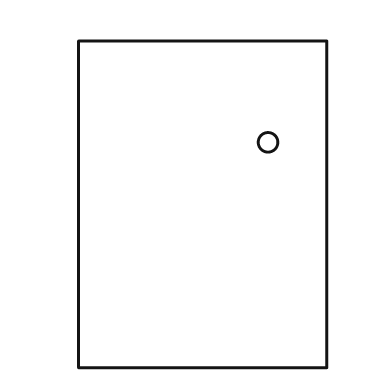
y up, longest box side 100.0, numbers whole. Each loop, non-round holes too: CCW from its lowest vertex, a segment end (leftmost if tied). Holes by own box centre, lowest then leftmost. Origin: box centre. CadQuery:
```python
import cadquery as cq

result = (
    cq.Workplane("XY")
    .moveTo(-38.0, -50.0)
    .lineTo(38.0, -50.0)
    .lineTo(38.0, 50.0)
    .lineTo(-38.0, 50.0)
    .close()
    .moveTo(20.0, 19.0)
    .circle(3.0)
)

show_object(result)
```